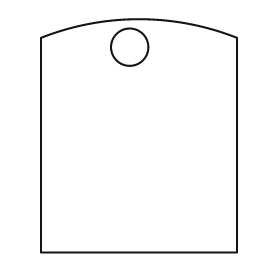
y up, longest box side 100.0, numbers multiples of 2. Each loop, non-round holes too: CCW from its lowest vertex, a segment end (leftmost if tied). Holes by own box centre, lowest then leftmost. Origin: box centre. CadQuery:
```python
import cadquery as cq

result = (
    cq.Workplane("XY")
    .moveTo(-42.0, -50.0)
    .lineTo(42.0, -50.0)
    .lineTo(42.0, 42.0)
    .threePointArc((0.0, 50.0), (-42.0, 42.0))
    .close()
    .moveTo(-4.0, 38.0)
    .circle(8.0)
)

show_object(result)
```